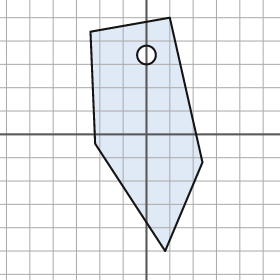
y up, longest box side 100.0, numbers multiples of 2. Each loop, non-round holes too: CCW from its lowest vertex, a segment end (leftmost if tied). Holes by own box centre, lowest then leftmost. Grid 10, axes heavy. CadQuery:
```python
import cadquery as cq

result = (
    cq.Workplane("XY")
    .moveTo(8.0, -50.0)
    .lineTo(24.0, -12.0)
    .lineTo(10.0, 50.0)
    .lineTo(-24.0, 44.0)
    .lineTo(-22.0, -4.0)
    .close()
    .moveTo(0.0, 34.0)
    .circle(4.0)
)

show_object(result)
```